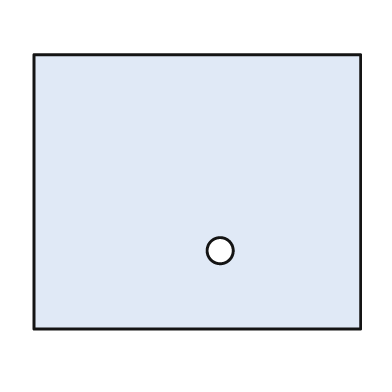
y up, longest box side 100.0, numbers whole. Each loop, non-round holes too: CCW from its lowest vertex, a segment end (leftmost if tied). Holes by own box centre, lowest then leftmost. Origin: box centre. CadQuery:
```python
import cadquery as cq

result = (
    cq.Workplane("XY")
    .moveTo(-50.0, -42.0)
    .lineTo(50.0, -42.0)
    .lineTo(50.0, 42.0)
    .lineTo(-50.0, 42.0)
    .close()
    .moveTo(7.0, -18.0)
    .circle(4.0)
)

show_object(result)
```